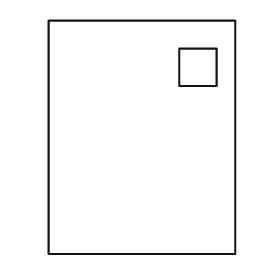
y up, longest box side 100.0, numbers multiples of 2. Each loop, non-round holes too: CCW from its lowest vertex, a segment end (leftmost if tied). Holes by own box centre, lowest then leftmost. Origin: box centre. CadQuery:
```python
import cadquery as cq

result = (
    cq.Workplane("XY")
    .moveTo(-40.0, -50.0)
    .lineTo(40.0, -50.0)
    .lineTo(40.0, 50.0)
    .lineTo(-40.0, 50.0)
    .close()
    .moveTo(16.0, 22.0)
    .lineTo(32.0, 22.0)
    .lineTo(32.0, 38.0)
    .lineTo(16.0, 38.0)
    .close()
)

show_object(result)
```